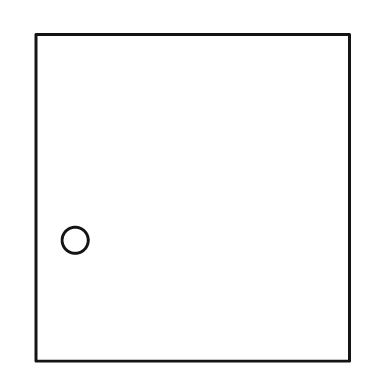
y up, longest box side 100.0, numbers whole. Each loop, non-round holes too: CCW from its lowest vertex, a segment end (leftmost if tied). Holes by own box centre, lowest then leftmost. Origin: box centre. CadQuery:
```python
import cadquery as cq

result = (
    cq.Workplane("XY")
    .moveTo(-48.0, -50.0)
    .lineTo(48.0, -50.0)
    .lineTo(48.0, 50.0)
    .lineTo(-48.0, 50.0)
    .close()
    .moveTo(-36.0, -13.0)
    .circle(4.0)
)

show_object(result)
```